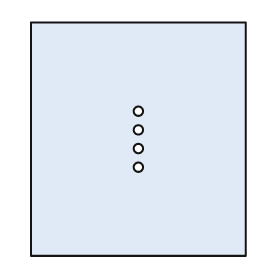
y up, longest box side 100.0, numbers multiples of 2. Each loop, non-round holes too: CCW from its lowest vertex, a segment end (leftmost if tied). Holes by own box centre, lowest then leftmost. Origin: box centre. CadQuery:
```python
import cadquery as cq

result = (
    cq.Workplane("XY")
    .moveTo(-46.0, -50.0)
    .lineTo(46.0, -50.0)
    .lineTo(46.0, 50.0)
    .lineTo(-46.0, 50.0)
    .close()
    .moveTo(0.0, -12.0)
    .circle(2.0)
    .moveTo(0.0, -4.0)
    .circle(2.0)
    .moveTo(0.0, 4.0)
    .circle(2.0)
    .moveTo(0.0, 12.0)
    .circle(2.0)
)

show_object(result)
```